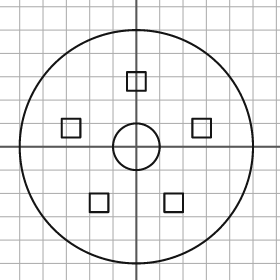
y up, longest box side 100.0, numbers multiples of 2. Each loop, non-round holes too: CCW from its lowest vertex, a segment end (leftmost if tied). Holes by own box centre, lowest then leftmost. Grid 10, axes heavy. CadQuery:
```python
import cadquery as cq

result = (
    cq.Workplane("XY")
    .moveTo(0.0, 0.0)
    .circle(50.0)
    .moveTo(-20.0, -28.0)
    .lineTo(-12.0, -28.0)
    .lineTo(-12.0, -20.0)
    .lineTo(-20.0, -20.0)
    .close()
    .moveTo(12.0, -28.0)
    .lineTo(20.0, -28.0)
    .lineTo(20.0, -20.0)
    .lineTo(12.0, -20.0)
    .close()
    .moveTo(0.0, 0.0)
    .circle(10.0)
    .moveTo(-32.0, 4.0)
    .lineTo(-24.0, 4.0)
    .lineTo(-24.0, 12.0)
    .lineTo(-32.0, 12.0)
    .close()
    .moveTo(24.0, 4.0)
    .lineTo(32.0, 4.0)
    .lineTo(32.0, 12.0)
    .lineTo(24.0, 12.0)
    .close()
    .moveTo(-4.0, 24.0)
    .lineTo(4.0, 24.0)
    .lineTo(4.0, 32.0)
    .lineTo(-4.0, 32.0)
    .close()
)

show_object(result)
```